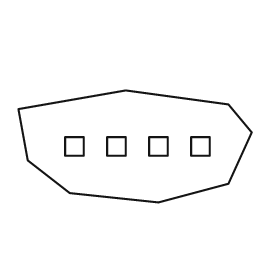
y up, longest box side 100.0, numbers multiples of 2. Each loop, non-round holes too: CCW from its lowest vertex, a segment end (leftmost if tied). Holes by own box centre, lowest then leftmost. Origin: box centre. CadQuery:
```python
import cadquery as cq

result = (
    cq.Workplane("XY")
    .moveTo(10.0, -24.0)
    .lineTo(40.0, -16.0)
    .lineTo(50.0, 6.0)
    .lineTo(40.0, 18.0)
    .lineTo(-4.0, 24.0)
    .lineTo(-50.0, 16.0)
    .lineTo(-46.0, -6.0)
    .lineTo(-28.0, -20.0)
    .close()
    .moveTo(-30.0, -4.0)
    .lineTo(-22.0, -4.0)
    .lineTo(-22.0, 4.0)
    .lineTo(-30.0, 4.0)
    .close()
    .moveTo(-12.0, -4.0)
    .lineTo(-4.0, -4.0)
    .lineTo(-4.0, 4.0)
    .lineTo(-12.0, 4.0)
    .close()
    .moveTo(6.0, -4.0)
    .lineTo(14.0, -4.0)
    .lineTo(14.0, 4.0)
    .lineTo(6.0, 4.0)
    .close()
    .moveTo(24.0, -4.0)
    .lineTo(32.0, -4.0)
    .lineTo(32.0, 4.0)
    .lineTo(24.0, 4.0)
    .close()
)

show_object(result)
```